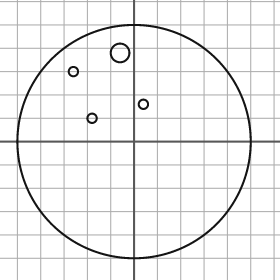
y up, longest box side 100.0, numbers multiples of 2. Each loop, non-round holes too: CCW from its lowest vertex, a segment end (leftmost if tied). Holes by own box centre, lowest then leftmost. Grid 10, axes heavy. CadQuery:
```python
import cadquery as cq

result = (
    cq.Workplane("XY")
    .moveTo(0.0, 0.0)
    .circle(50.0)
    .moveTo(-18.0, 10.0)
    .circle(2.0)
    .moveTo(4.0, 16.0)
    .circle(2.0)
    .moveTo(-26.0, 30.0)
    .circle(2.0)
    .moveTo(-6.0, 38.0)
    .circle(4.0)
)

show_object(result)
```